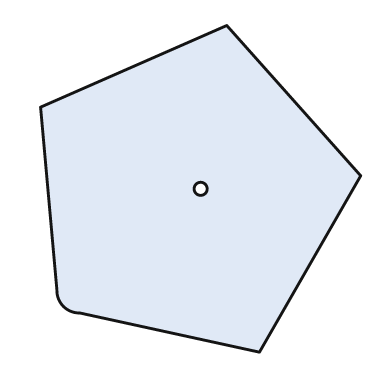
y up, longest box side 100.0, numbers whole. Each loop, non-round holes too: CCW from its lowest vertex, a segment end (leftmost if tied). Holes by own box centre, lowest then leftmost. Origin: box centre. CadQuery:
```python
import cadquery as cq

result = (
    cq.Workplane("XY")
    .moveTo(18.0, -50.0)
    .lineTo(49.0, 4.0)
    .lineTo(8.0, 50.0)
    .lineTo(-49.0, 25.0)
    .lineTo(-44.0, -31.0)
    .threePointArc((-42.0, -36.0), (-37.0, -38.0))
    .close()
    .moveTo(0.0, 0.0)
    .circle(2.0)
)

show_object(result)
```